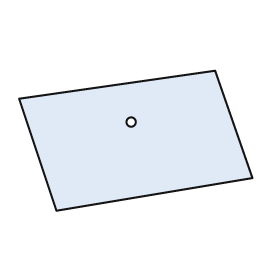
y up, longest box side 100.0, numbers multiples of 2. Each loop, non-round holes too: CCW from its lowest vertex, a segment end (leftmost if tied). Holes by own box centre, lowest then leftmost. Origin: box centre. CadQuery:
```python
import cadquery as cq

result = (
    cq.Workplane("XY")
    .moveTo(-34.0, -30.0)
    .lineTo(50.0, -16.0)
    .lineTo(34.0, 30.0)
    .lineTo(-50.0, 18.0)
    .close()
    .moveTo(-2.0, 8.0)
    .circle(2.0)
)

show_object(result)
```